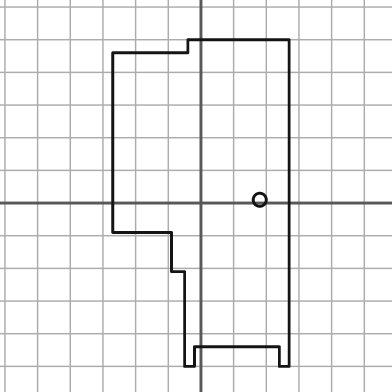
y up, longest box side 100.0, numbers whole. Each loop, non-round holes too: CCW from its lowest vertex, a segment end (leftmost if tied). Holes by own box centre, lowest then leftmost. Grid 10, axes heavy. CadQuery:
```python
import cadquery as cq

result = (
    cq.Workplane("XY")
    .moveTo(-5.0, -50.0)
    .lineTo(-2.0, -50.0)
    .lineTo(-2.0, -44.0)
    .lineTo(24.0, -44.0)
    .lineTo(24.0, -50.0)
    .lineTo(27.0, -50.0)
    .lineTo(27.0, 50.0)
    .lineTo(-4.0, 50.0)
    .lineTo(-4.0, 46.0)
    .lineTo(-27.0, 46.0)
    .lineTo(-27.0, -9.0)
    .lineTo(-9.0, -9.0)
    .lineTo(-9.0, -21.0)
    .lineTo(-5.0, -21.0)
    .close()
    .moveTo(18.0, 1.0)
    .circle(2.0)
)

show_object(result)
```